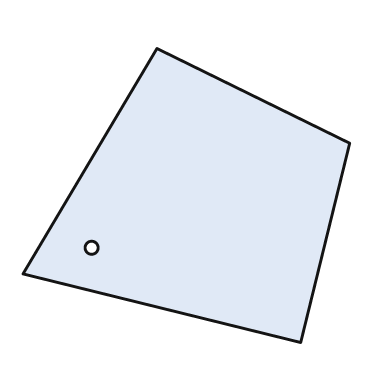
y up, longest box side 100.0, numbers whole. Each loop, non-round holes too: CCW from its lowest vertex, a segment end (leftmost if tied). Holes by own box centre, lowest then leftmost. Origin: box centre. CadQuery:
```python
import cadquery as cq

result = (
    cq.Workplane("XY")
    .moveTo(35.0, -45.0)
    .lineTo(50.0, 16.0)
    .lineTo(-9.0, 45.0)
    .lineTo(-50.0, -24.0)
    .close()
    .moveTo(-29.0, -16.0)
    .circle(2.0)
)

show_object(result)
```